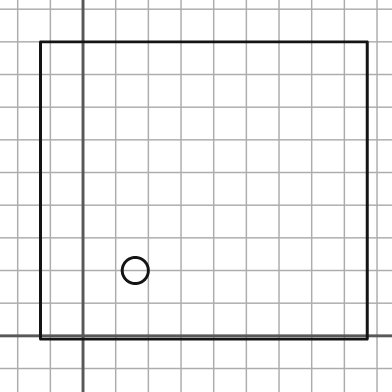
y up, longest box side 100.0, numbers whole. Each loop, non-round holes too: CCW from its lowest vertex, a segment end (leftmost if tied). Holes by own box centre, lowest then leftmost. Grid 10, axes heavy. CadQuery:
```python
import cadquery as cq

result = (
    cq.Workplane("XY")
    .moveTo(-13.0, -1.0)
    .lineTo(87.0, -1.0)
    .lineTo(87.0, 90.0)
    .lineTo(-13.0, 90.0)
    .close()
    .moveTo(16.0, 20.0)
    .circle(4.0)
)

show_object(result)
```